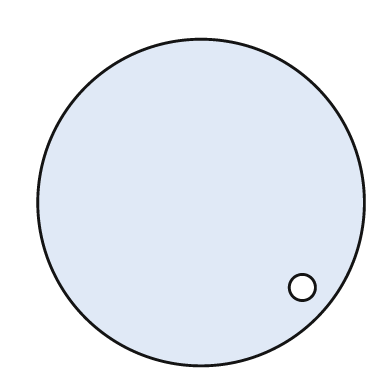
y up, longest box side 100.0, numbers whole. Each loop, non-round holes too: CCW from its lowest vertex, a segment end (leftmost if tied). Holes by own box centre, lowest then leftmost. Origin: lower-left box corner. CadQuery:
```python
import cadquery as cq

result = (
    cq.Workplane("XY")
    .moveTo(50.0, 50.0)
    .circle(50.0)
    .moveTo(81.0, 24.0)
    .circle(4.0)
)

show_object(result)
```